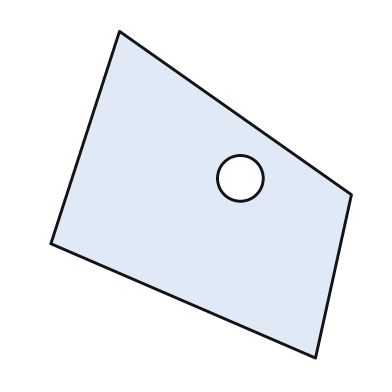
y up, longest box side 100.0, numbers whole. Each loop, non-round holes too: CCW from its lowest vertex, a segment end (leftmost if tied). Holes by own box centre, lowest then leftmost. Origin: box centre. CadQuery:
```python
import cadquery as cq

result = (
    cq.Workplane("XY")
    .moveTo(35.0, -50.0)
    .lineTo(46.0, 0.0)
    .lineTo(-25.0, 50.0)
    .lineTo(-46.0, -15.0)
    .close()
    .moveTo(12.0, 5.0)
    .circle(7.0)
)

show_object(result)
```